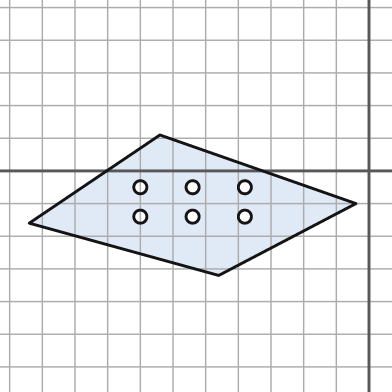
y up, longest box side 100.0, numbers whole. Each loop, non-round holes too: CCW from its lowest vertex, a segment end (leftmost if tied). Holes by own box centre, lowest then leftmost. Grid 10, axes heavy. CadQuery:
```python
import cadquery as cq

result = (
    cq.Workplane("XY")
    .moveTo(-46.0, -32.0)
    .lineTo(-4.0, -10.0)
    .lineTo(-64.0, 11.0)
    .lineTo(-104.0, -16.0)
    .close()
    .moveTo(-70.0, -14.0)
    .circle(2.0)
    .moveTo(-54.0, -14.0)
    .circle(2.0)
    .moveTo(-38.0, -14.0)
    .circle(2.0)
    .moveTo(-70.0, -5.0)
    .circle(2.0)
    .moveTo(-54.0, -5.0)
    .circle(2.0)
    .moveTo(-38.0, -5.0)
    .circle(2.0)
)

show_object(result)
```